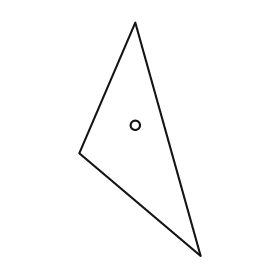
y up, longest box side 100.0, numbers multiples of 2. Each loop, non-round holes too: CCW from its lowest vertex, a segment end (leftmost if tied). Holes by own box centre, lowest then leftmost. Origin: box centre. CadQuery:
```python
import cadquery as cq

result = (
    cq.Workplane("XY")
    .moveTo(26.0, -50.0)
    .lineTo(-2.0, 50.0)
    .lineTo(-26.0, -6.0)
    .close()
    .moveTo(-2.0, 6.0)
    .circle(2.0)
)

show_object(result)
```